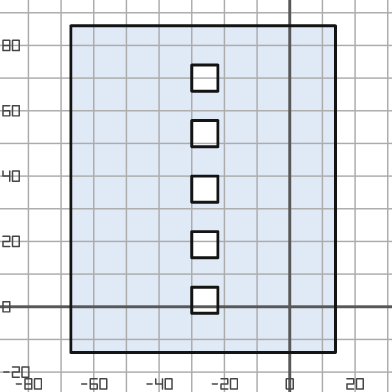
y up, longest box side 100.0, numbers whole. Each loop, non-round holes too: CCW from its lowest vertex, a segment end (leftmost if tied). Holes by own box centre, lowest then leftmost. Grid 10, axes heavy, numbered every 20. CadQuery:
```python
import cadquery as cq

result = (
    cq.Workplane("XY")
    .moveTo(-67.0, -14.0)
    .lineTo(14.0, -14.0)
    .lineTo(14.0, 86.0)
    .lineTo(-67.0, 86.0)
    .close()
    .moveTo(-30.0, -2.0)
    .lineTo(-22.0, -2.0)
    .lineTo(-22.0, 6.0)
    .lineTo(-30.0, 6.0)
    .close()
    .moveTo(-30.0, 15.0)
    .lineTo(-22.0, 15.0)
    .lineTo(-22.0, 23.0)
    .lineTo(-30.0, 23.0)
    .close()
    .moveTo(-30.0, 32.0)
    .lineTo(-22.0, 32.0)
    .lineTo(-22.0, 40.0)
    .lineTo(-30.0, 40.0)
    .close()
    .moveTo(-30.0, 49.0)
    .lineTo(-22.0, 49.0)
    .lineTo(-22.0, 57.0)
    .lineTo(-30.0, 57.0)
    .close()
    .moveTo(-30.0, 66.0)
    .lineTo(-22.0, 66.0)
    .lineTo(-22.0, 74.0)
    .lineTo(-30.0, 74.0)
    .close()
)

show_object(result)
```